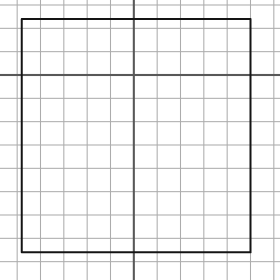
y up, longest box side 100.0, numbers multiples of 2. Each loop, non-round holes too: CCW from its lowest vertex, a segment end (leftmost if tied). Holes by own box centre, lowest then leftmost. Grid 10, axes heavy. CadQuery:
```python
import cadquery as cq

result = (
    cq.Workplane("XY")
    .moveTo(-48.0, -76.0)
    .lineTo(50.0, -76.0)
    .lineTo(50.0, 24.0)
    .lineTo(-48.0, 24.0)
    .close()
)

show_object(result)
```